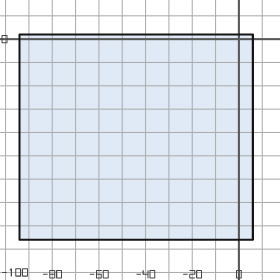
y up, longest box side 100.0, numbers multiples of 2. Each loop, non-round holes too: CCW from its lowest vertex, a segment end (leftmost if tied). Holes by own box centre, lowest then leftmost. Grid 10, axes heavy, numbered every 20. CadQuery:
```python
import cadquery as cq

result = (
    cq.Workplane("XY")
    .moveTo(-94.0, -86.0)
    .lineTo(6.0, -86.0)
    .lineTo(6.0, 2.0)
    .lineTo(-94.0, 2.0)
    .close()
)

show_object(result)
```